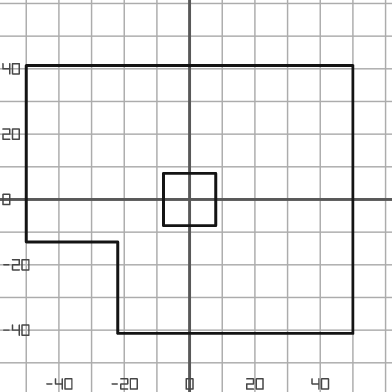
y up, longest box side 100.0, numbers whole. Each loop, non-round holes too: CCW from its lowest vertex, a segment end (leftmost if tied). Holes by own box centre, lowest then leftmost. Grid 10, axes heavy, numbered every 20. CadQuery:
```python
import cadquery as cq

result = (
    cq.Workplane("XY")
    .moveTo(-22.0, -41.0)
    .lineTo(50.0, -41.0)
    .lineTo(50.0, 41.0)
    .lineTo(-50.0, 41.0)
    .lineTo(-50.0, -13.0)
    .lineTo(-22.0, -13.0)
    .close()
    .moveTo(-8.0, -8.0)
    .lineTo(8.0, -8.0)
    .lineTo(8.0, 8.0)
    .lineTo(-8.0, 8.0)
    .close()
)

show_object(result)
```